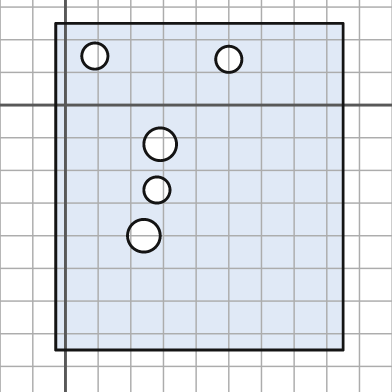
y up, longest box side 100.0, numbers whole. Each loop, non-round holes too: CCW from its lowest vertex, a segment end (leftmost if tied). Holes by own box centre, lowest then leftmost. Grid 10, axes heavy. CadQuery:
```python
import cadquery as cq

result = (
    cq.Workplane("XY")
    .moveTo(-3.0, -75.0)
    .lineTo(85.0, -75.0)
    .lineTo(85.0, 25.0)
    .lineTo(-3.0, 25.0)
    .close()
    .moveTo(24.0, -40.0)
    .circle(5.0)
    .moveTo(28.0, -26.0)
    .circle(4.0)
    .moveTo(29.0, -12.0)
    .circle(5.0)
    .moveTo(50.0, 14.0)
    .circle(4.0)
    .moveTo(9.0, 15.0)
    .circle(4.0)
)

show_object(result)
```